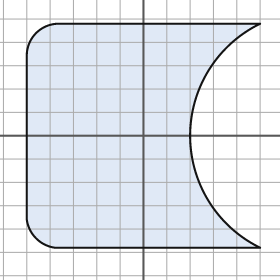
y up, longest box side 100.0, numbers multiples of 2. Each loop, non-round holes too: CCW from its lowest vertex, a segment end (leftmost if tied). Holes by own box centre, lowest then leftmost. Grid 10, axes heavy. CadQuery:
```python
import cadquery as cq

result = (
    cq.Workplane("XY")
    .moveTo(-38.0, -48.0)
    .lineTo(50.0, -48.0)
    .threePointArc((20.0, 0.0), (50.0, 48.0))
    .lineTo(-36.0, 48.0)
    .threePointArc((-46.0, 44.0), (-50.0, 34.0))
    .lineTo(-50.0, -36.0)
    .threePointArc((-46.0, -44.0), (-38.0, -48.0))
    .close()
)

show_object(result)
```